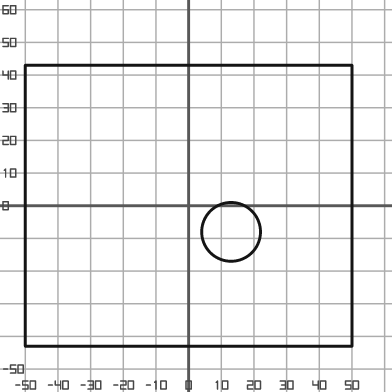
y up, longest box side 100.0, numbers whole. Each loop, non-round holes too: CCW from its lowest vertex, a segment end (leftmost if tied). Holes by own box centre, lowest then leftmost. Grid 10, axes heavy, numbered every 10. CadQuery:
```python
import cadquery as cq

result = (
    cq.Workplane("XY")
    .moveTo(-50.0, -43.0)
    .lineTo(50.0, -43.0)
    .lineTo(50.0, 43.0)
    .lineTo(-50.0, 43.0)
    .close()
    .moveTo(13.0, -8.0)
    .circle(9.0)
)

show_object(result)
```